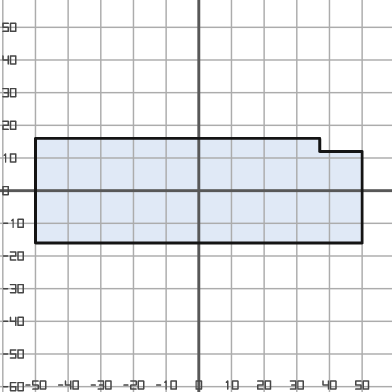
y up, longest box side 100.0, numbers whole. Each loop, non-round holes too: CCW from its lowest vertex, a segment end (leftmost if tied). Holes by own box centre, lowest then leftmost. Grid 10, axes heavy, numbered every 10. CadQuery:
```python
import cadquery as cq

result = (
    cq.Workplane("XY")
    .moveTo(-50.0, -16.0)
    .lineTo(50.0, -16.0)
    .lineTo(50.0, 12.0)
    .lineTo(37.0, 12.0)
    .lineTo(37.0, 16.0)
    .lineTo(-50.0, 16.0)
    .close()
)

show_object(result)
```